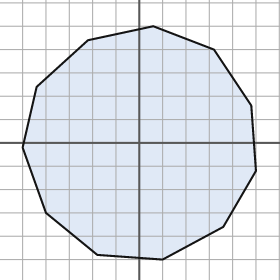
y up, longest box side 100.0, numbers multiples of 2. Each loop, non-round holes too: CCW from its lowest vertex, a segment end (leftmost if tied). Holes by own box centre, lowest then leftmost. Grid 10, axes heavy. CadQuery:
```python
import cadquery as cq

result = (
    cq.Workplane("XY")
    .moveTo(10.0, -50.0)
    .lineTo(36.0, -36.0)
    .lineTo(50.0, -12.0)
    .lineTo(48.0, 16.0)
    .lineTo(32.0, 40.0)
    .lineTo(6.0, 50.0)
    .lineTo(-22.0, 44.0)
    .lineTo(-44.0, 24.0)
    .lineTo(-50.0, -2.0)
    .lineTo(-40.0, -30.0)
    .lineTo(-18.0, -48.0)
    .close()
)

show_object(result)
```